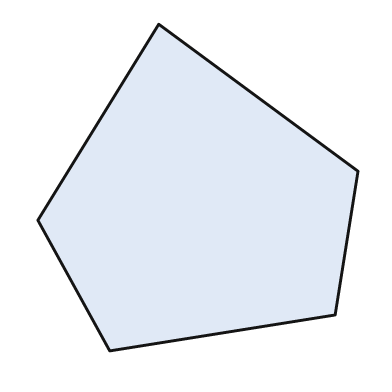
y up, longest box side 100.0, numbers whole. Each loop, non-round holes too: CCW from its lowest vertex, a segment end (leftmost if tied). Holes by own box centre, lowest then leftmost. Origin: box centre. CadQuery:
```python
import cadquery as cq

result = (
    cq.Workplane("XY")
    .moveTo(-27.0, -50.0)
    .lineTo(42.0, -39.0)
    .lineTo(49.0, 5.0)
    .lineTo(-12.0, 50.0)
    .lineTo(-49.0, -10.0)
    .close()
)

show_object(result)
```